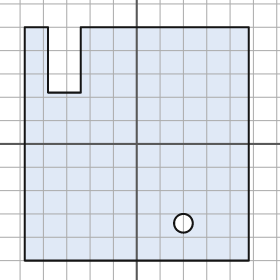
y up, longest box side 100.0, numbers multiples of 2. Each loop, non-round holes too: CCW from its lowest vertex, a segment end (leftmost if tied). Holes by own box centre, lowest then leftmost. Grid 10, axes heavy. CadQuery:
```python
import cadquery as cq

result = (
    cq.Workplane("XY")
    .moveTo(-48.0, -50.0)
    .lineTo(48.0, -50.0)
    .lineTo(48.0, 50.0)
    .lineTo(-24.0, 50.0)
    .lineTo(-24.0, 22.0)
    .lineTo(-38.0, 22.0)
    .lineTo(-38.0, 50.0)
    .lineTo(-48.0, 50.0)
    .close()
    .moveTo(20.0, -34.0)
    .circle(4.0)
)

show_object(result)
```